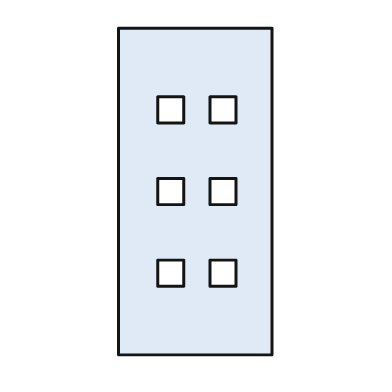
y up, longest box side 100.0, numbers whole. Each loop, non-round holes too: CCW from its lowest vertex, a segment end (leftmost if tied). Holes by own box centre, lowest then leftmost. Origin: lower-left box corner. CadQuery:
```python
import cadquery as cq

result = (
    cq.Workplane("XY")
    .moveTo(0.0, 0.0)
    .lineTo(47.0, 0.0)
    .lineTo(47.0, 100.0)
    .lineTo(0.0, 100.0)
    .close()
    .moveTo(12.0, 21.0)
    .lineTo(20.0, 21.0)
    .lineTo(20.0, 29.0)
    .lineTo(12.0, 29.0)
    .close()
    .moveTo(28.0, 21.0)
    .lineTo(36.0, 21.0)
    .lineTo(36.0, 29.0)
    .lineTo(28.0, 29.0)
    .close()
    .moveTo(12.0, 46.0)
    .lineTo(20.0, 46.0)
    .lineTo(20.0, 54.0)
    .lineTo(12.0, 54.0)
    .close()
    .moveTo(28.0, 46.0)
    .lineTo(36.0, 46.0)
    .lineTo(36.0, 54.0)
    .lineTo(28.0, 54.0)
    .close()
    .moveTo(12.0, 71.0)
    .lineTo(20.0, 71.0)
    .lineTo(20.0, 79.0)
    .lineTo(12.0, 79.0)
    .close()
    .moveTo(28.0, 71.0)
    .lineTo(36.0, 71.0)
    .lineTo(36.0, 79.0)
    .lineTo(28.0, 79.0)
    .close()
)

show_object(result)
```